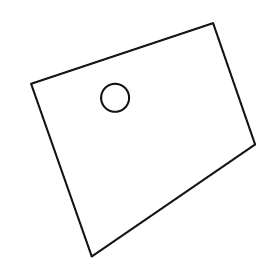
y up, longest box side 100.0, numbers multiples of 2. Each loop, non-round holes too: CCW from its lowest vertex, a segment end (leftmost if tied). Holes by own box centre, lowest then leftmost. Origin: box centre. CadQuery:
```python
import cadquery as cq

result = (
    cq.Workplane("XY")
    .moveTo(-22.0, -50.0)
    .lineTo(48.0, -2.0)
    .lineTo(30.0, 50.0)
    .lineTo(-48.0, 24.0)
    .close()
    .moveTo(-12.0, 18.0)
    .circle(6.0)
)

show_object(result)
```